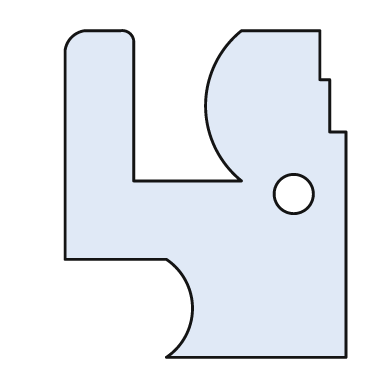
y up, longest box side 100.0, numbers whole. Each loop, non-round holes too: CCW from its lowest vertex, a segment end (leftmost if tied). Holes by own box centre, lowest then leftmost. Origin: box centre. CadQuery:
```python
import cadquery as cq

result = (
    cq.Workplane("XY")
    .moveTo(-12.0, -50.0)
    .lineTo(43.0, -50.0)
    .lineTo(43.0, 19.0)
    .lineTo(38.0, 19.0)
    .lineTo(38.0, 35.0)
    .lineTo(35.0, 35.0)
    .lineTo(35.0, 50.0)
    .lineTo(11.0, 50.0)
    .threePointArc((0.0, 27.0), (11.0, 4.0))
    .lineTo(-22.0, 4.0)
    .lineTo(-22.0, 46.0)
    .threePointArc((-23.0, 49.0), (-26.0, 50.0))
    .lineTo(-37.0, 50.0)
    .threePointArc((-41.0, 48.0), (-43.0, 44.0))
    .lineTo(-43.0, -20.0)
    .lineTo(-12.0, -20.0)
    .threePointArc((-4.0, -35.0), (-12.0, -50.0))
    .close()
    .moveTo(27.0, 0.0)
    .circle(6.0)
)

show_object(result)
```